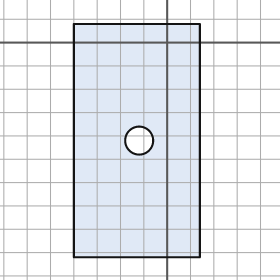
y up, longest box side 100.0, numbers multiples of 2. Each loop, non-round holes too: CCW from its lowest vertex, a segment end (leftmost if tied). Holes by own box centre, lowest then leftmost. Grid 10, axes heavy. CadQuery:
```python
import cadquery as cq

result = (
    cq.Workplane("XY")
    .moveTo(-40.0, -92.0)
    .lineTo(14.0, -92.0)
    .lineTo(14.0, 8.0)
    .lineTo(-40.0, 8.0)
    .close()
    .moveTo(-12.0, -42.0)
    .circle(6.0)
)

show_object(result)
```